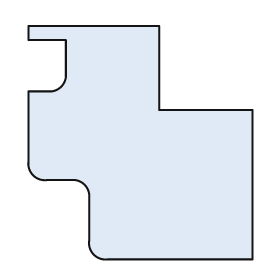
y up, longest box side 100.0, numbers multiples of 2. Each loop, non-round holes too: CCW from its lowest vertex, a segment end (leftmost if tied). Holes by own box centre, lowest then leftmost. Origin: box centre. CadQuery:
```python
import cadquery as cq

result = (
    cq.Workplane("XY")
    .moveTo(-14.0, -50.0)
    .lineTo(48.0, -50.0)
    .lineTo(48.0, 14.0)
    .lineTo(8.0, 14.0)
    .lineTo(8.0, 50.0)
    .lineTo(-48.0, 50.0)
    .lineTo(-48.0, 44.0)
    .lineTo(-32.0, 44.0)
    .lineTo(-32.0, 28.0)
    .threePointArc((-34.0, 24.0), (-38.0, 22.0))
    .lineTo(-48.0, 22.0)
    .lineTo(-48.0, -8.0)
    .threePointArc((-46.0, -14.0), (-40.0, -16.0))
    .lineTo(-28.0, -16.0)
    .threePointArc((-24.0, -18.0), (-22.0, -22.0))
    .lineTo(-22.0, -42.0)
    .threePointArc((-20.0, -48.0), (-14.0, -50.0))
    .close()
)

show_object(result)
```